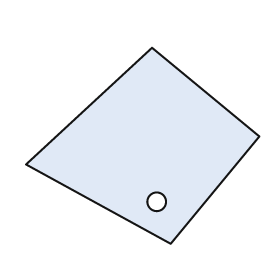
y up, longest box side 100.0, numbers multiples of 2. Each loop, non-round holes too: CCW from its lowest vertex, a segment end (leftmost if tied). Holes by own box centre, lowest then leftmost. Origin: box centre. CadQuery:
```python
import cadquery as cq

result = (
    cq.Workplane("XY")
    .moveTo(12.0, -42.0)
    .lineTo(50.0, 4.0)
    .lineTo(4.0, 42.0)
    .lineTo(-50.0, -8.0)
    .close()
    .moveTo(6.0, -24.0)
    .circle(4.0)
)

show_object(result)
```